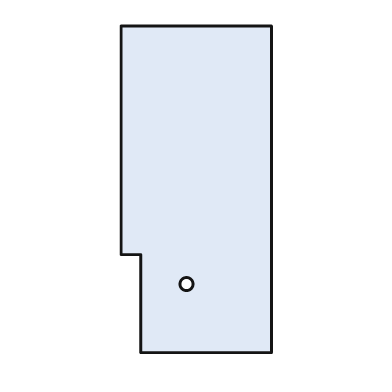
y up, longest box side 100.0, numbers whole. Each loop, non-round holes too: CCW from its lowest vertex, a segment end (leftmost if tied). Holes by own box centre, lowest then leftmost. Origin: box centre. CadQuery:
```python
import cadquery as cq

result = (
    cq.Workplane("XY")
    .moveTo(-17.0, -50.0)
    .lineTo(23.0, -50.0)
    .lineTo(23.0, 50.0)
    .lineTo(-23.0, 50.0)
    .lineTo(-23.0, -20.0)
    .lineTo(-17.0, -20.0)
    .close()
    .moveTo(-3.0, -29.0)
    .circle(2.0)
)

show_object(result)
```